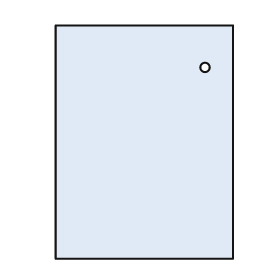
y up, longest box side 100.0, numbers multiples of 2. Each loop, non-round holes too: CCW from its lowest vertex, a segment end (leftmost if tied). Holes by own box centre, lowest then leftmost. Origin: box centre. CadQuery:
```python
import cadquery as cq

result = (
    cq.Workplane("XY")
    .moveTo(-38.0, -50.0)
    .lineTo(38.0, -50.0)
    .lineTo(38.0, 50.0)
    .lineTo(-38.0, 50.0)
    .close()
    .moveTo(26.0, 32.0)
    .circle(2.0)
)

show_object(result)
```